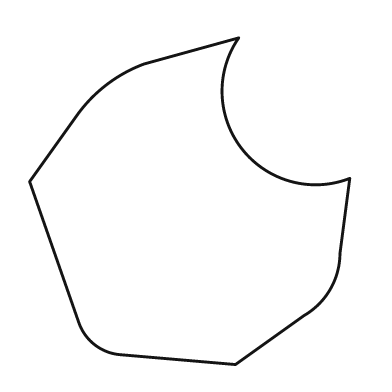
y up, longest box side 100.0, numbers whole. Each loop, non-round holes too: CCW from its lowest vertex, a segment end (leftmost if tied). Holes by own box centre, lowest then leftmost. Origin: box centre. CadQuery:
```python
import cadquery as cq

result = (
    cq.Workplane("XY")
    .moveTo(14.0, -50.0)
    .lineTo(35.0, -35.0)
    .threePointArc((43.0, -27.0), (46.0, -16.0))
    .lineTo(49.0, 7.0)
    .threePointArc((16.0, 16.0), (15.0, 50.0))
    .lineTo(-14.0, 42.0)
    .threePointArc((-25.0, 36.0), (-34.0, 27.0))
    .lineTo(-49.0, 6.0)
    .lineTo(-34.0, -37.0)
    .threePointArc((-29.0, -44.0), (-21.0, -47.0))
    .close()
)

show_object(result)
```